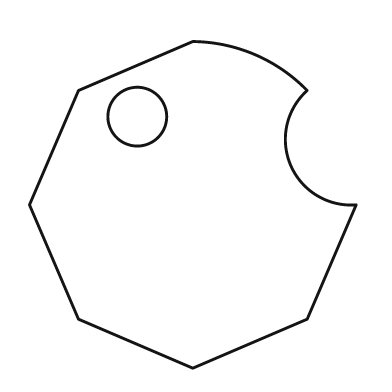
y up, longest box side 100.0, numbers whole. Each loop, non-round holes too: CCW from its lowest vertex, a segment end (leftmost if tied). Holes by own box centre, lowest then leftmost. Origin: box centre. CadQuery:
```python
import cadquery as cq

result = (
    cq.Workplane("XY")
    .moveTo(0.0, -50.0)
    .lineTo(35.0, -35.0)
    .lineTo(50.0, 0.0)
    .threePointArc((30.0, 12.0), (35.0, 35.0))
    .threePointArc((19.0, 46.0), (0.0, 50.0))
    .lineTo(-35.0, 35.0)
    .lineTo(-50.0, 0.0)
    .lineTo(-35.0, -35.0)
    .close()
    .moveTo(-17.0, 27.0)
    .circle(9.0)
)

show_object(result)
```